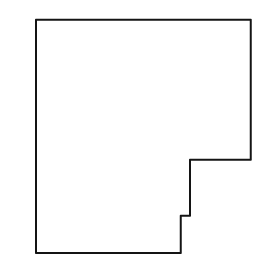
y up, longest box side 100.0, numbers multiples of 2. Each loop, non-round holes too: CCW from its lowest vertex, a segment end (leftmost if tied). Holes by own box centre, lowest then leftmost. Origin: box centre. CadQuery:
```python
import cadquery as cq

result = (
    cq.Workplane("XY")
    .moveTo(-46.0, -50.0)
    .lineTo(16.0, -50.0)
    .lineTo(16.0, -34.0)
    .lineTo(20.0, -34.0)
    .lineTo(20.0, -10.0)
    .lineTo(46.0, -10.0)
    .lineTo(46.0, 50.0)
    .lineTo(-46.0, 50.0)
    .close()
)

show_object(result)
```